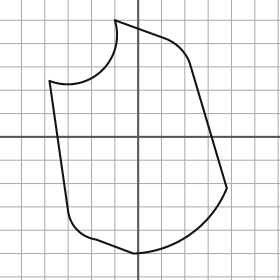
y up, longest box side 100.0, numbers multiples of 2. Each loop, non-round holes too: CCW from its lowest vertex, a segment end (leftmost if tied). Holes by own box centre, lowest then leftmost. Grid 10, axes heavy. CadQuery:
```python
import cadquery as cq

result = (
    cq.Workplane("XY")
    .moveTo(-2.0, -50.0)
    .threePointArc((22.0, -42.0), (38.0, -22.0))
    .lineTo(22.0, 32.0)
    .threePointArc((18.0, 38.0), (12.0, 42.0))
    .lineTo(-10.0, 50.0)
    .threePointArc((-16.0, 28.0), (-38.0, 24.0))
    .lineTo(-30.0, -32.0)
    .threePointArc((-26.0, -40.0), (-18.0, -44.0))
    .close()
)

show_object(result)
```